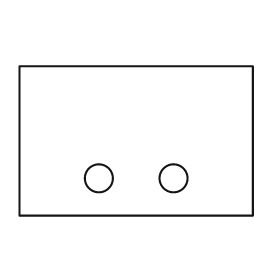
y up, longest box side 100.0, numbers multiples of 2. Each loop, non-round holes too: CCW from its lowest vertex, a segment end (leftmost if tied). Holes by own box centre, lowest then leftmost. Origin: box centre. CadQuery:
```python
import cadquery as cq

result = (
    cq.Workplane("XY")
    .moveTo(-50.0, -32.0)
    .lineTo(50.0, -32.0)
    .lineTo(50.0, 32.0)
    .lineTo(-50.0, 32.0)
    .close()
    .moveTo(-16.0, -16.0)
    .circle(6.0)
    .moveTo(16.0, -16.0)
    .circle(6.0)
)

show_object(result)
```